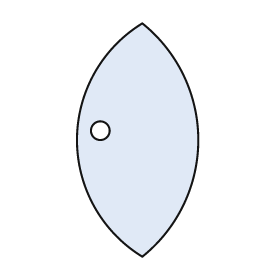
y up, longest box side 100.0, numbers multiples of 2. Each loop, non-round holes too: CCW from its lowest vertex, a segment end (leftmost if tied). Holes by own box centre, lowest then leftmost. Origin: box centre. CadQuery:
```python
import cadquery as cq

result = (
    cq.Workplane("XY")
    .moveTo(2.0, -50.0)
    .threePointArc((26.0, 0.0), (2.0, 50.0))
    .threePointArc((-26.0, 0.0), (2.0, -50.0))
    .close()
    .moveTo(-16.0, 4.0)
    .circle(4.0)
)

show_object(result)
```